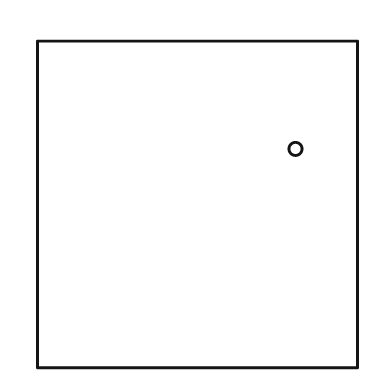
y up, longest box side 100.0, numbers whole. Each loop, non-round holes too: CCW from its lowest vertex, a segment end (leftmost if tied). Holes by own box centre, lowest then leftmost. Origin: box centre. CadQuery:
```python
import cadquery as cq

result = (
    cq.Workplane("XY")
    .moveTo(-49.0, -50.0)
    .lineTo(49.0, -50.0)
    .lineTo(49.0, 50.0)
    .lineTo(-49.0, 50.0)
    .close()
    .moveTo(30.0, 17.0)
    .circle(2.0)
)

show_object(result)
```